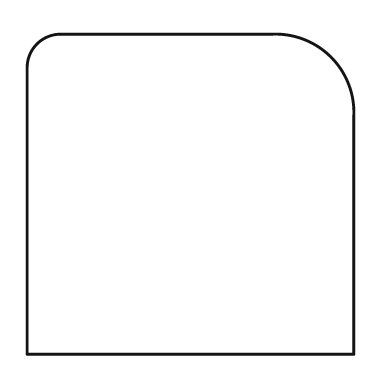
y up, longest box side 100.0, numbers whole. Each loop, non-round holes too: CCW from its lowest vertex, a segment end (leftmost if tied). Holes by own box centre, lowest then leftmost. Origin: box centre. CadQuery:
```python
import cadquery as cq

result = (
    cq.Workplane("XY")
    .moveTo(-50.0, -49.0)
    .lineTo(50.0, -49.0)
    .lineTo(50.0, 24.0)
    .threePointArc((43.0, 42.0), (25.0, 49.0))
    .lineTo(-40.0, 49.0)
    .threePointArc((-47.0, 46.0), (-50.0, 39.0))
    .close()
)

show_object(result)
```